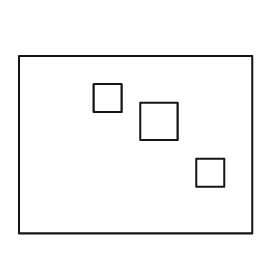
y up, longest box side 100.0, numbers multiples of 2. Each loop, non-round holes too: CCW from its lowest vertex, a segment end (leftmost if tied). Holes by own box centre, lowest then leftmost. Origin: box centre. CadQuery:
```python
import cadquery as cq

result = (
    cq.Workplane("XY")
    .moveTo(-50.0, -38.0)
    .lineTo(50.0, -38.0)
    .lineTo(50.0, 38.0)
    .lineTo(-50.0, 38.0)
    .close()
    .moveTo(26.0, -18.0)
    .lineTo(38.0, -18.0)
    .lineTo(38.0, -6.0)
    .lineTo(26.0, -6.0)
    .close()
    .moveTo(2.0, 2.0)
    .lineTo(18.0, 2.0)
    .lineTo(18.0, 18.0)
    .lineTo(2.0, 18.0)
    .close()
    .moveTo(-18.0, 14.0)
    .lineTo(-6.0, 14.0)
    .lineTo(-6.0, 26.0)
    .lineTo(-18.0, 26.0)
    .close()
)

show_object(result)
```